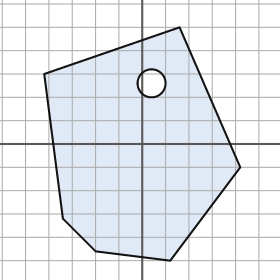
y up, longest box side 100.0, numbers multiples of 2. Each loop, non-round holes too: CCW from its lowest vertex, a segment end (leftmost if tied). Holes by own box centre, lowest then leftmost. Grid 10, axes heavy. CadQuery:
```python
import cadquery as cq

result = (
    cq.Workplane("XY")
    .moveTo(12.0, -50.0)
    .lineTo(42.0, -10.0)
    .lineTo(16.0, 50.0)
    .lineTo(-42.0, 30.0)
    .lineTo(-34.0, -32.0)
    .lineTo(-20.0, -46.0)
    .close()
    .moveTo(4.0, 26.0)
    .circle(6.0)
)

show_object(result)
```